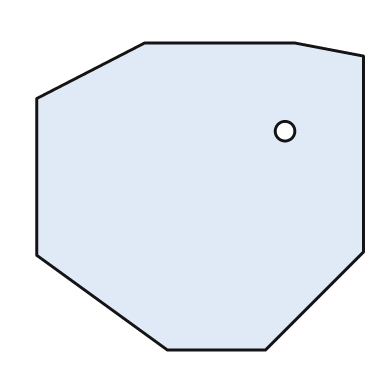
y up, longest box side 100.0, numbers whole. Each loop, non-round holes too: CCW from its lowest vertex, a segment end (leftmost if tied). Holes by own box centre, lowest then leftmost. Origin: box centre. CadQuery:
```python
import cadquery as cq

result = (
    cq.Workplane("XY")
    .moveTo(-10.0, -47.0)
    .lineTo(20.0, -47.0)
    .lineTo(50.0, -17.0)
    .lineTo(50.0, 43.0)
    .lineTo(29.0, 47.0)
    .lineTo(-17.0, 47.0)
    .lineTo(-50.0, 30.0)
    .lineTo(-50.0, -18.0)
    .close()
    .moveTo(26.0, 20.0)
    .circle(3.0)
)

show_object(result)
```